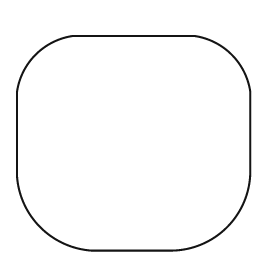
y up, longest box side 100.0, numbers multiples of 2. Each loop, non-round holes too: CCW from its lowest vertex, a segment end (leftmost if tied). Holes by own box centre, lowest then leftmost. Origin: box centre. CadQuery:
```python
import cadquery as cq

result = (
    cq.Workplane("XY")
    .moveTo(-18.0, -46.0)
    .lineTo(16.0, -46.0)
    .threePointArc((40.0, -36.0), (50.0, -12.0))
    .lineTo(50.0, 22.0)
    .threePointArc((42.0, 38.0), (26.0, 46.0))
    .lineTo(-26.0, 46.0)
    .threePointArc((-42.0, 38.0), (-50.0, 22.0))
    .lineTo(-50.0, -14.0)
    .threePointArc((-40.0, -36.0), (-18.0, -46.0))
    .close()
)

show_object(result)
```